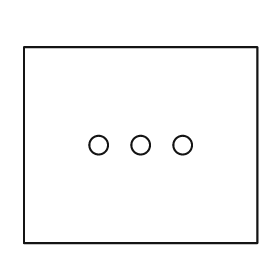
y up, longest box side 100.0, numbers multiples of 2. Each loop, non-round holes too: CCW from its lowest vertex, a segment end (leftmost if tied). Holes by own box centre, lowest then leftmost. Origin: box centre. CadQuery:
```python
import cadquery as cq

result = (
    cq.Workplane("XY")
    .moveTo(-50.0, -42.0)
    .lineTo(50.0, -42.0)
    .lineTo(50.0, 42.0)
    .lineTo(-50.0, 42.0)
    .close()
    .moveTo(-18.0, 0.0)
    .circle(4.0)
    .moveTo(0.0, 0.0)
    .circle(4.0)
    .moveTo(18.0, 0.0)
    .circle(4.0)
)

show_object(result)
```